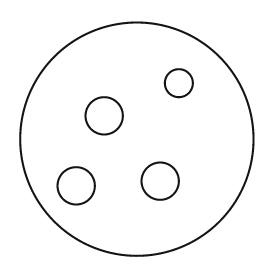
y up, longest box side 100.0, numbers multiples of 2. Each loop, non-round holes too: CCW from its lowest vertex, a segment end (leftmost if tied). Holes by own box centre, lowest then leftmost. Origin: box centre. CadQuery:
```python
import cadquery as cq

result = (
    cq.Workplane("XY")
    .moveTo(0.0, 0.0)
    .circle(50.0)
    .moveTo(-26.0, -20.0)
    .circle(8.0)
    .moveTo(10.0, -18.0)
    .circle(8.0)
    .moveTo(-14.0, 10.0)
    .circle(8.0)
    .moveTo(18.0, 24.0)
    .circle(6.0)
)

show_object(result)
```